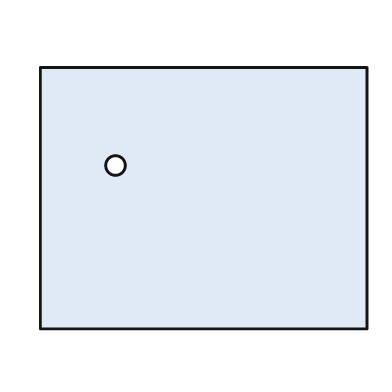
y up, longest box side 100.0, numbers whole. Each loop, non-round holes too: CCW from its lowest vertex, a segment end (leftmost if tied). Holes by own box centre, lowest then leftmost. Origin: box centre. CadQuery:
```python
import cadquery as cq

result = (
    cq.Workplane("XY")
    .moveTo(-50.0, -40.0)
    .lineTo(50.0, -40.0)
    .lineTo(50.0, 40.0)
    .lineTo(-50.0, 40.0)
    .close()
    .moveTo(-27.0, 10.0)
    .circle(3.0)
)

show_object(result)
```